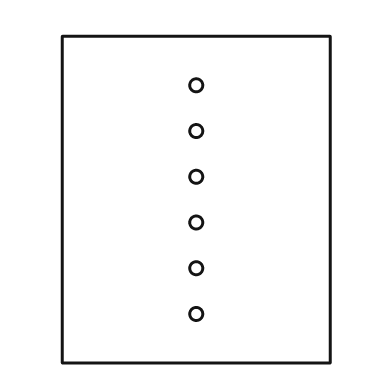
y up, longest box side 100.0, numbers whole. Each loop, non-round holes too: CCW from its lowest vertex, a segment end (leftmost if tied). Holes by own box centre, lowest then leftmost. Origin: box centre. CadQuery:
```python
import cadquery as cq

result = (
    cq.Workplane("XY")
    .moveTo(-41.0, -50.0)
    .lineTo(41.0, -50.0)
    .lineTo(41.0, 50.0)
    .lineTo(-41.0, 50.0)
    .close()
    .moveTo(0.0, -35.0)
    .circle(2.0)
    .moveTo(0.0, -21.0)
    .circle(2.0)
    .moveTo(0.0, -7.0)
    .circle(2.0)
    .moveTo(0.0, 7.0)
    .circle(2.0)
    .moveTo(0.0, 21.0)
    .circle(2.0)
    .moveTo(0.0, 35.0)
    .circle(2.0)
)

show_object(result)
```